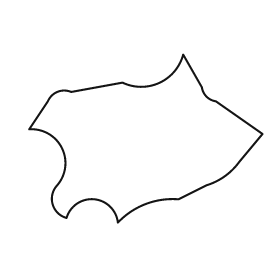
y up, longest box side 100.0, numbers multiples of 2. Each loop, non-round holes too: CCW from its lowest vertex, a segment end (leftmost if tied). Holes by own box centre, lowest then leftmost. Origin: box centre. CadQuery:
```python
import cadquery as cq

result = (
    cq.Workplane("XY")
    .moveTo(-12.0, -36.0)
    .threePointArc((0.0, -28.0), (14.0, -26.0))
    .lineTo(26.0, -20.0)
    .threePointArc((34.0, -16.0), (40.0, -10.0))
    .lineTo(50.0, 2.0)
    .lineTo(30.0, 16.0)
    .threePointArc((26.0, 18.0), (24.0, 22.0))
    .lineTo(16.0, 36.0)
    .threePointArc((6.0, 24.0), (-10.0, 24.0))
    .lineTo(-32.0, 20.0)
    .threePointArc((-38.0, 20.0), (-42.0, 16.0))
    .lineTo(-50.0, 4.0)
    .threePointArc((-36.0, -4.0), (-38.0, -20.0))
    .threePointArc((-40.0, -28.0), (-34.0, -34.0))
    .threePointArc((-22.0, -26.0), (-12.0, -36.0))
    .close()
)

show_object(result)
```